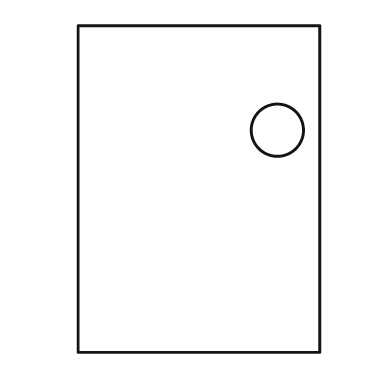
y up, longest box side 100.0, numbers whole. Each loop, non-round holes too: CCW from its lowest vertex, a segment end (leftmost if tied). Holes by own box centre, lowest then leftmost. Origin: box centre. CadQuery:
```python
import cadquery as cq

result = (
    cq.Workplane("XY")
    .moveTo(-37.0, -50.0)
    .lineTo(37.0, -50.0)
    .lineTo(37.0, 50.0)
    .lineTo(-37.0, 50.0)
    .close()
    .moveTo(24.0, 18.0)
    .circle(8.0)
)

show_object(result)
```